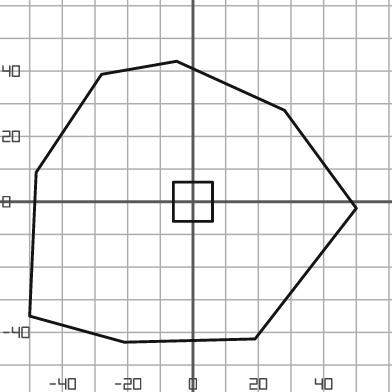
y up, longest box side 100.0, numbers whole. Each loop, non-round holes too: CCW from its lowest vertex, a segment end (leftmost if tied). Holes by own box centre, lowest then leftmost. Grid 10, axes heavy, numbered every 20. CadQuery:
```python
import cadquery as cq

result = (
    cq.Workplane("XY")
    .moveTo(-21.0, -43.0)
    .lineTo(19.0, -42.0)
    .lineTo(50.0, -2.0)
    .lineTo(28.0, 28.0)
    .lineTo(-5.0, 43.0)
    .lineTo(-28.0, 39.0)
    .lineTo(-48.0, 9.0)
    .lineTo(-50.0, -35.0)
    .close()
    .moveTo(-6.0, -6.0)
    .lineTo(6.0, -6.0)
    .lineTo(6.0, 6.0)
    .lineTo(-6.0, 6.0)
    .close()
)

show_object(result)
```